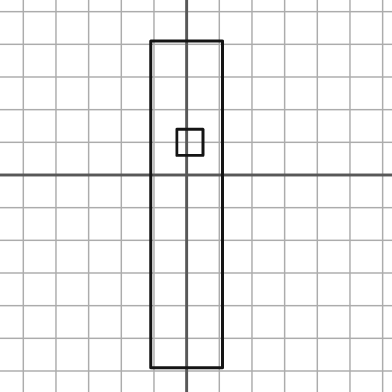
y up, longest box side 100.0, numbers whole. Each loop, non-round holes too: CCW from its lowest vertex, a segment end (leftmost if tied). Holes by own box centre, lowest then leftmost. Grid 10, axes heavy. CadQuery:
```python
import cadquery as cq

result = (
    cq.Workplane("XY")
    .moveTo(-11.0, -59.0)
    .lineTo(11.0, -59.0)
    .lineTo(11.0, 41.0)
    .lineTo(-11.0, 41.0)
    .close()
    .moveTo(-3.0, 6.0)
    .lineTo(5.0, 6.0)
    .lineTo(5.0, 14.0)
    .lineTo(-3.0, 14.0)
    .close()
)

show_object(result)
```